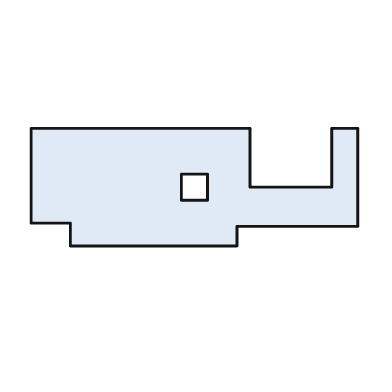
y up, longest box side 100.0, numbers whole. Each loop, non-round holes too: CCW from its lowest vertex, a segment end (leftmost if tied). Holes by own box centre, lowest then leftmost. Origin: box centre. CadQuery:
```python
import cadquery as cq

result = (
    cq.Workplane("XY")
    .moveTo(-38.0, -18.0)
    .lineTo(13.0, -18.0)
    .lineTo(13.0, -12.0)
    .lineTo(50.0, -12.0)
    .lineTo(50.0, 18.0)
    .lineTo(42.0, 18.0)
    .lineTo(42.0, 0.0)
    .lineTo(17.0, 0.0)
    .lineTo(17.0, 18.0)
    .lineTo(-50.0, 18.0)
    .lineTo(-50.0, -11.0)
    .lineTo(-38.0, -11.0)
    .close()
    .moveTo(-4.0, -4.0)
    .lineTo(4.0, -4.0)
    .lineTo(4.0, 4.0)
    .lineTo(-4.0, 4.0)
    .close()
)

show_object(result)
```